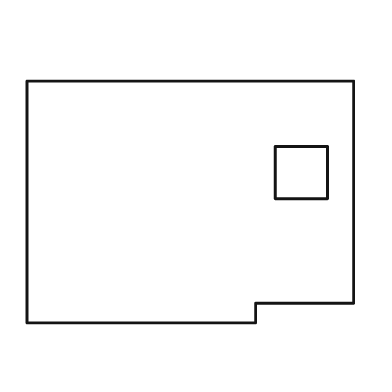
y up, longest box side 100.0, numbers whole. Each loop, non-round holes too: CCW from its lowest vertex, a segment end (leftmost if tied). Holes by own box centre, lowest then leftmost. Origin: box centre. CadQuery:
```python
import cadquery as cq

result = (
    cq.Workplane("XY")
    .moveTo(-50.0, -37.0)
    .lineTo(20.0, -37.0)
    .lineTo(20.0, -31.0)
    .lineTo(50.0, -31.0)
    .lineTo(50.0, 37.0)
    .lineTo(-50.0, 37.0)
    .close()
    .moveTo(26.0, 1.0)
    .lineTo(42.0, 1.0)
    .lineTo(42.0, 17.0)
    .lineTo(26.0, 17.0)
    .close()
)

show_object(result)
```